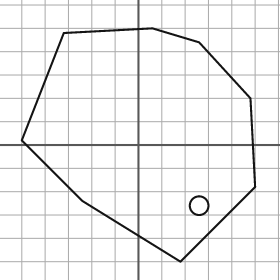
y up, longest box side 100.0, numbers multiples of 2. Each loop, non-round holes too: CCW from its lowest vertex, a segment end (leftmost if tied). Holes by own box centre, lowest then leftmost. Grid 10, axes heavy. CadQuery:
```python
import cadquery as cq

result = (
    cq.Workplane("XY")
    .moveTo(18.0, -50.0)
    .lineTo(50.0, -18.0)
    .lineTo(48.0, 20.0)
    .lineTo(26.0, 44.0)
    .lineTo(6.0, 50.0)
    .lineTo(-32.0, 48.0)
    .lineTo(-50.0, 2.0)
    .lineTo(-24.0, -24.0)
    .close()
    .moveTo(26.0, -26.0)
    .circle(4.0)
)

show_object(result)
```